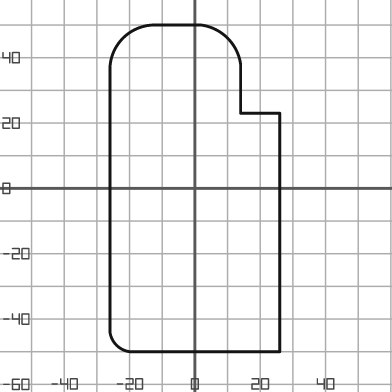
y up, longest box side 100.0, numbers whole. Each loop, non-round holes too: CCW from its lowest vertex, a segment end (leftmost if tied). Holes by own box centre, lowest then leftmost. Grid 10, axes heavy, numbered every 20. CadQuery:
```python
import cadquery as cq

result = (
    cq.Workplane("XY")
    .moveTo(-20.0, -50.0)
    .lineTo(26.0, -50.0)
    .lineTo(26.0, 23.0)
    .lineTo(14.0, 23.0)
    .lineTo(14.0, 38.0)
    .threePointArc((10.0, 46.0), (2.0, 50.0))
    .lineTo(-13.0, 50.0)
    .threePointArc((-22.0, 46.0), (-26.0, 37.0))
    .lineTo(-26.0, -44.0)
    .threePointArc((-24.0, -48.0), (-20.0, -50.0))
    .close()
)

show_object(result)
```